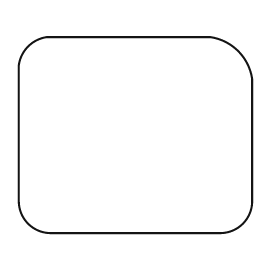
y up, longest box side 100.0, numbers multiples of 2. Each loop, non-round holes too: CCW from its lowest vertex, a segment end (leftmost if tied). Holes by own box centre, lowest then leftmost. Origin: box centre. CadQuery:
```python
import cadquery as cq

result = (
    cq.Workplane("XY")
    .moveTo(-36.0, -42.0)
    .lineTo(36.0, -42.0)
    .threePointArc((46.0, -38.0), (50.0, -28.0))
    .lineTo(50.0, 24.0)
    .threePointArc((44.0, 36.0), (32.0, 42.0))
    .lineTo(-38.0, 42.0)
    .threePointArc((-46.0, 38.0), (-50.0, 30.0))
    .lineTo(-50.0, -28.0)
    .threePointArc((-46.0, -38.0), (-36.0, -42.0))
    .close()
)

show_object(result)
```